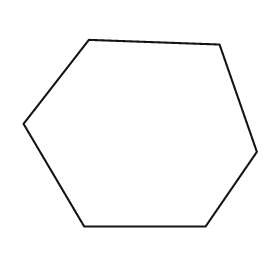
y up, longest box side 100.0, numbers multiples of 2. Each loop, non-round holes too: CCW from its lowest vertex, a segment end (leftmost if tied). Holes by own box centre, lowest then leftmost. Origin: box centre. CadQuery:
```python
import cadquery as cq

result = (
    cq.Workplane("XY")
    .moveTo(-24.0, -40.0)
    .lineTo(28.0, -40.0)
    .lineTo(50.0, -8.0)
    .lineTo(34.0, 38.0)
    .lineTo(-22.0, 40.0)
    .lineTo(-50.0, 4.0)
    .close()
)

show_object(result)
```